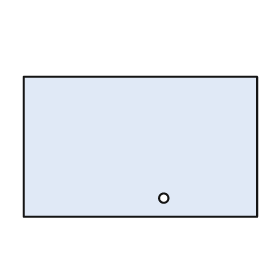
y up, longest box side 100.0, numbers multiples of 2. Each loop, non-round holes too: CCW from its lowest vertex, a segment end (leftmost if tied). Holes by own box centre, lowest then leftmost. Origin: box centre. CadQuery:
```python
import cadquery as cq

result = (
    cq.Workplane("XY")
    .moveTo(-50.0, -30.0)
    .lineTo(50.0, -30.0)
    .lineTo(50.0, 30.0)
    .lineTo(-50.0, 30.0)
    .close()
    .moveTo(10.0, -22.0)
    .circle(2.0)
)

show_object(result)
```